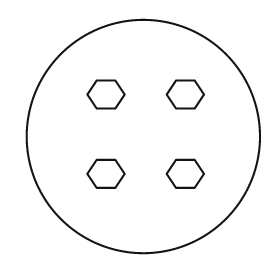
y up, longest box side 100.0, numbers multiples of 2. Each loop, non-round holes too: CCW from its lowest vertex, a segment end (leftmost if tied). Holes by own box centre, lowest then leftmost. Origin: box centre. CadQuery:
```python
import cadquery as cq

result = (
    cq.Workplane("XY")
    .moveTo(0.0, 0.0)
    .circle(50.0)
    .moveTo(-20.0, -22.0)
    .lineTo(-12.0, -22.0)
    .lineTo(-8.0, -16.0)
    .lineTo(-12.0, -10.0)
    .lineTo(-20.0, -10.0)
    .lineTo(-24.0, -16.0)
    .close()
    .moveTo(14.0, -22.0)
    .lineTo(22.0, -22.0)
    .lineTo(26.0, -16.0)
    .lineTo(22.0, -10.0)
    .lineTo(14.0, -10.0)
    .lineTo(10.0, -16.0)
    .close()
    .moveTo(-20.0, 12.0)
    .lineTo(-12.0, 12.0)
    .lineTo(-8.0, 18.0)
    .lineTo(-12.0, 24.0)
    .lineTo(-20.0, 24.0)
    .lineTo(-24.0, 18.0)
    .close()
    .moveTo(14.0, 12.0)
    .lineTo(22.0, 12.0)
    .lineTo(26.0, 18.0)
    .lineTo(22.0, 24.0)
    .lineTo(14.0, 24.0)
    .lineTo(10.0, 18.0)
    .close()
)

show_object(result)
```